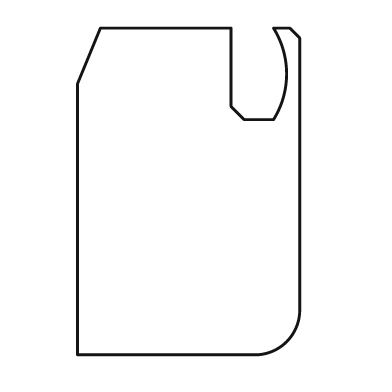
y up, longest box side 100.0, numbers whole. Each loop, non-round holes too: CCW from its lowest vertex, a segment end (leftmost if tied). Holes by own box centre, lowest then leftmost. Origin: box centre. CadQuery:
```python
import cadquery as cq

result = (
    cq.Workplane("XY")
    .moveTo(-34.0, -50.0)
    .lineTo(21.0, -50.0)
    .threePointArc((30.0, -46.0), (34.0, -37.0))
    .lineTo(34.0, 47.0)
    .lineTo(31.0, 50.0)
    .lineTo(26.0, 50.0)
    .threePointArc((30.0, 36.0), (26.0, 22.0))
    .lineTo(17.0, 22.0)
    .lineTo(13.0, 26.0)
    .lineTo(13.0, 50.0)
    .lineTo(-27.0, 50.0)
    .lineTo(-34.0, 33.0)
    .close()
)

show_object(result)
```